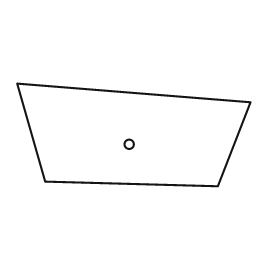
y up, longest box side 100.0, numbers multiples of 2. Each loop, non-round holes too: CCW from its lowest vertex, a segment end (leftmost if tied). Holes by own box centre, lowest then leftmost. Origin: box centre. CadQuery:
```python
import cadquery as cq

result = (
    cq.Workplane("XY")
    .moveTo(36.0, -22.0)
    .lineTo(50.0, 14.0)
    .lineTo(-50.0, 22.0)
    .lineTo(-38.0, -20.0)
    .close()
    .moveTo(-2.0, -4.0)
    .circle(2.0)
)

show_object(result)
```